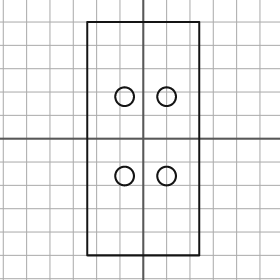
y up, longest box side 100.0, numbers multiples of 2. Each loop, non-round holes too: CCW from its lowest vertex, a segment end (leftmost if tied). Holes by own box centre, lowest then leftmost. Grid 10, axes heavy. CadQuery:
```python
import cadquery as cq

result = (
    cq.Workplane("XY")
    .moveTo(-24.0, -50.0)
    .lineTo(24.0, -50.0)
    .lineTo(24.0, 50.0)
    .lineTo(-24.0, 50.0)
    .close()
    .moveTo(-8.0, -16.0)
    .circle(4.0)
    .moveTo(10.0, -16.0)
    .circle(4.0)
    .moveTo(-8.0, 18.0)
    .circle(4.0)
    .moveTo(10.0, 18.0)
    .circle(4.0)
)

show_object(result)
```